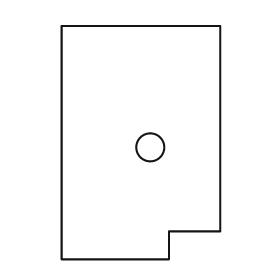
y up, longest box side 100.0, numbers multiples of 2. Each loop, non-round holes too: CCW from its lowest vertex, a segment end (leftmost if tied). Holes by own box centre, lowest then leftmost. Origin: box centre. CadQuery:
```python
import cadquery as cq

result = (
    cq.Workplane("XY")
    .moveTo(-34.0, -50.0)
    .lineTo(12.0, -50.0)
    .lineTo(12.0, -38.0)
    .lineTo(34.0, -38.0)
    .lineTo(34.0, 50.0)
    .lineTo(-34.0, 50.0)
    .close()
    .moveTo(4.0, -2.0)
    .circle(6.0)
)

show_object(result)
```